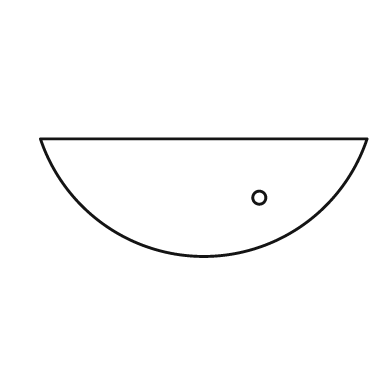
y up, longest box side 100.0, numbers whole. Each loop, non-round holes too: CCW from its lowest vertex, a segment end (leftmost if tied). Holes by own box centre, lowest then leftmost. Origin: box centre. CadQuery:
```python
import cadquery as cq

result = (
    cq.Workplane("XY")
    .moveTo(-50.0, 18.0)
    .threePointArc((0.0, -18.0), (50.0, 18.0))
    .close()
    .moveTo(17.0, 0.0)
    .circle(2.0)
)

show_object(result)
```